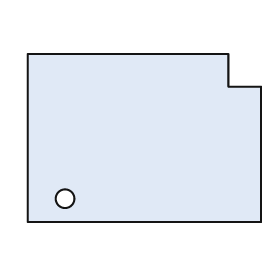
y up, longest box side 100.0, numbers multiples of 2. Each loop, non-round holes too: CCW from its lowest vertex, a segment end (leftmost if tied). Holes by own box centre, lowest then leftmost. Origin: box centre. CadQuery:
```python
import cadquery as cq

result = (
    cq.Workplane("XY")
    .moveTo(-50.0, -36.0)
    .lineTo(50.0, -36.0)
    .lineTo(50.0, 22.0)
    .lineTo(36.0, 22.0)
    .lineTo(36.0, 36.0)
    .lineTo(-50.0, 36.0)
    .close()
    .moveTo(-34.0, -26.0)
    .circle(4.0)
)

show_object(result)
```